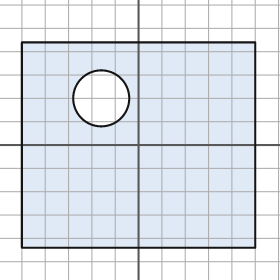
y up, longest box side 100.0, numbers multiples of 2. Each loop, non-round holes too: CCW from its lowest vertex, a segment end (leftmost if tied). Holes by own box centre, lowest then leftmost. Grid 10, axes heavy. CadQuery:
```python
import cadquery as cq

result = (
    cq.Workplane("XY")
    .moveTo(-50.0, -44.0)
    .lineTo(50.0, -44.0)
    .lineTo(50.0, 44.0)
    .lineTo(-50.0, 44.0)
    .close()
    .moveTo(-16.0, 20.0)
    .circle(12.0)
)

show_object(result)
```